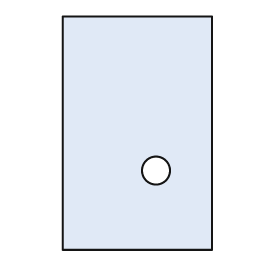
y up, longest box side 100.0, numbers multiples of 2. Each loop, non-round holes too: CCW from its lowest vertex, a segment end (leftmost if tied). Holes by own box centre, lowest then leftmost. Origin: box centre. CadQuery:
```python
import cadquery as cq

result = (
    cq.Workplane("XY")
    .moveTo(-32.0, -50.0)
    .lineTo(32.0, -50.0)
    .lineTo(32.0, 50.0)
    .lineTo(-32.0, 50.0)
    .close()
    .moveTo(8.0, -16.0)
    .circle(6.0)
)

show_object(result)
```